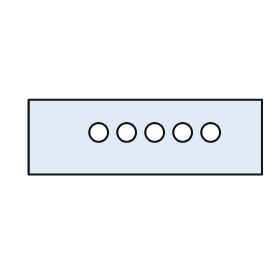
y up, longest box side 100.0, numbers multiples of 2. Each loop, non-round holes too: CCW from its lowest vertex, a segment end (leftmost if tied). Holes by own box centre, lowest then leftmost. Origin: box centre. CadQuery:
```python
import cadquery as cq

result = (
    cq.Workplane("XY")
    .moveTo(-50.0, -16.0)
    .lineTo(50.0, -16.0)
    .lineTo(50.0, 16.0)
    .lineTo(-50.0, 16.0)
    .close()
    .moveTo(-20.0, 2.0)
    .circle(4.0)
    .moveTo(-8.0, 2.0)
    .circle(4.0)
    .moveTo(4.0, 2.0)
    .circle(4.0)
    .moveTo(16.0, 2.0)
    .circle(4.0)
    .moveTo(28.0, 2.0)
    .circle(4.0)
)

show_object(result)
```